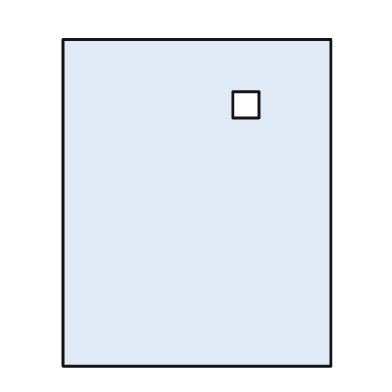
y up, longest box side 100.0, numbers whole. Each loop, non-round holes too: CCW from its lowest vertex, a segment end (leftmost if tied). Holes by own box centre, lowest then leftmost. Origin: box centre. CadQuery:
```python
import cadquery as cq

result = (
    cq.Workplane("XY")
    .moveTo(-41.0, -50.0)
    .lineTo(41.0, -50.0)
    .lineTo(41.0, 50.0)
    .lineTo(-41.0, 50.0)
    .close()
    .moveTo(11.0, 26.0)
    .lineTo(19.0, 26.0)
    .lineTo(19.0, 34.0)
    .lineTo(11.0, 34.0)
    .close()
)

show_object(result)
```